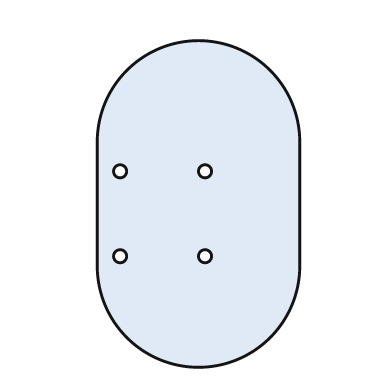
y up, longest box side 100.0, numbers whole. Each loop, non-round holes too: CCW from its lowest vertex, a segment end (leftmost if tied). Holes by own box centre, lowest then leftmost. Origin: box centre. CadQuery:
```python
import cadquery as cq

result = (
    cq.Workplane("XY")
    .moveTo(-31.0, -19.0)
    .threePointArc((0.0, -50.0), (31.0, -19.0))
    .lineTo(31.0, 19.0)
    .threePointArc((0.0, 50.0), (-31.0, 19.0))
    .close()
    .moveTo(-24.0, -16.0)
    .circle(2.0)
    .moveTo(2.0, -16.0)
    .circle(2.0)
    .moveTo(-24.0, 10.0)
    .circle(2.0)
    .moveTo(2.0, 10.0)
    .circle(2.0)
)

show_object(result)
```